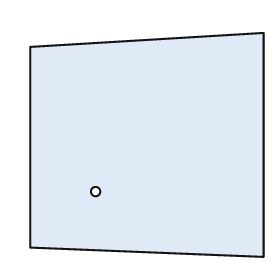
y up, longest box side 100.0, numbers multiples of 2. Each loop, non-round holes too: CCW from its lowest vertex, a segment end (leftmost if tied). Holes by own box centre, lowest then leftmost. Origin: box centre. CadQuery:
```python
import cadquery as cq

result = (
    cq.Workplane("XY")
    .moveTo(50.0, -48.0)
    .lineTo(50.0, 48.0)
    .lineTo(-50.0, 42.0)
    .lineTo(-50.0, -44.0)
    .close()
    .moveTo(-22.0, -20.0)
    .circle(2.0)
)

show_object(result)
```